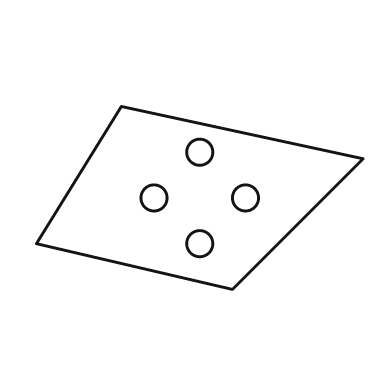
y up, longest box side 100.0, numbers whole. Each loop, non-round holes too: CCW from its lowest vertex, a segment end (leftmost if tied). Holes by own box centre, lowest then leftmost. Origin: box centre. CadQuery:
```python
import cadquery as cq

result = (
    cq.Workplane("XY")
    .moveTo(10.0, -28.0)
    .lineTo(50.0, 12.0)
    .lineTo(-24.0, 28.0)
    .lineTo(-50.0, -14.0)
    .close()
    .moveTo(0.0, -14.0)
    .circle(4.0)
    .moveTo(-14.0, 0.0)
    .circle(4.0)
    .moveTo(14.0, 0.0)
    .circle(4.0)
    .moveTo(0.0, 14.0)
    .circle(4.0)
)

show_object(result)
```